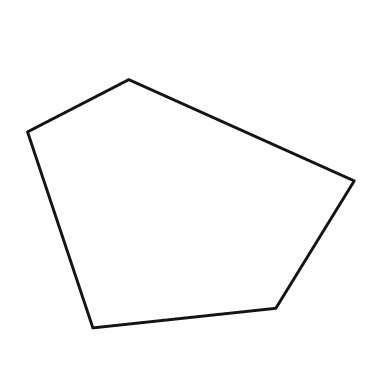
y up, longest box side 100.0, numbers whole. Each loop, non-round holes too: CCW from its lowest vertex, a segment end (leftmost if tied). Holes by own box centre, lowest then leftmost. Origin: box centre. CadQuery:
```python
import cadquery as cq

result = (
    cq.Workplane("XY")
    .moveTo(-30.0, -38.0)
    .lineTo(26.0, -32.0)
    .lineTo(50.0, 7.0)
    .lineTo(-19.0, 38.0)
    .lineTo(-50.0, 22.0)
    .close()
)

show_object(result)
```